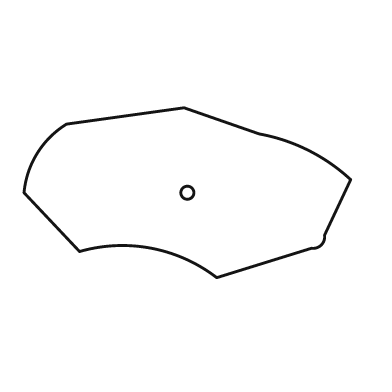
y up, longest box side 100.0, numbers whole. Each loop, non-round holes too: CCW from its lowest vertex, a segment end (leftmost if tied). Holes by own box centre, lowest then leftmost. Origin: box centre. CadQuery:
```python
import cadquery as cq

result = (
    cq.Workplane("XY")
    .moveTo(9.0, -26.0)
    .lineTo(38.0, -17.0)
    .threePointArc((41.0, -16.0), (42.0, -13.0))
    .lineTo(50.0, 4.0)
    .threePointArc((37.0, 13.0), (22.0, 18.0))
    .lineTo(-1.0, 26.0)
    .lineTo(-37.0, 21.0)
    .threePointArc((-46.0, 12.0), (-50.0, 0.0))
    .lineTo(-33.0, -18.0)
    .threePointArc((-11.0, -17.0), (9.0, -26.0))
    .close()
    .moveTo(0.0, 0.0)
    .circle(2.0)
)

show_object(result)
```